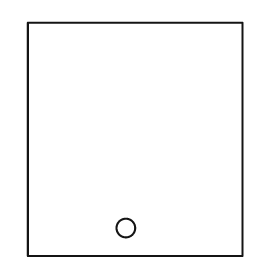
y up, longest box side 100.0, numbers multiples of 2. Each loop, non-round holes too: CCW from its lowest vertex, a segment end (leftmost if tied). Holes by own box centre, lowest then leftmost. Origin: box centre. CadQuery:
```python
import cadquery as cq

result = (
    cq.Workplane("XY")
    .moveTo(-46.0, -50.0)
    .lineTo(46.0, -50.0)
    .lineTo(46.0, 50.0)
    .lineTo(-46.0, 50.0)
    .close()
    .moveTo(-4.0, -38.0)
    .circle(4.0)
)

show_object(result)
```